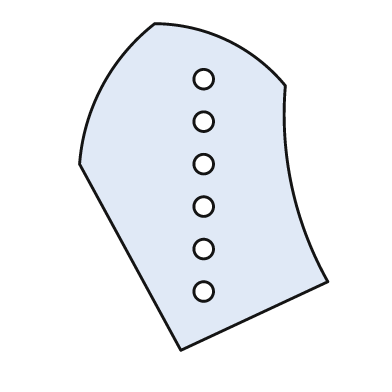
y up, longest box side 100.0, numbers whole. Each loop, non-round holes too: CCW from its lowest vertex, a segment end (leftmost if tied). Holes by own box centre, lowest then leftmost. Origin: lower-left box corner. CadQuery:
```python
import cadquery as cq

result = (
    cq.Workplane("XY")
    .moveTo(31.0, 0.0)
    .lineTo(76.0, 21.0)
    .threePointArc((65.0, 50.0), (63.0, 81.0))
    .threePointArc((45.0, 95.0), (23.0, 100.0))
    .threePointArc((7.0, 81.0), (0.0, 57.0))
    .close()
    .moveTo(38.0, 18.0)
    .circle(3.0)
    .moveTo(38.0, 31.0)
    .circle(3.0)
    .moveTo(38.0, 44.0)
    .circle(3.0)
    .moveTo(38.0, 57.0)
    .circle(3.0)
    .moveTo(38.0, 70.0)
    .circle(3.0)
    .moveTo(38.0, 83.0)
    .circle(3.0)
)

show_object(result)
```